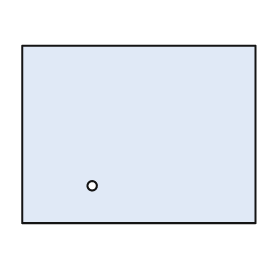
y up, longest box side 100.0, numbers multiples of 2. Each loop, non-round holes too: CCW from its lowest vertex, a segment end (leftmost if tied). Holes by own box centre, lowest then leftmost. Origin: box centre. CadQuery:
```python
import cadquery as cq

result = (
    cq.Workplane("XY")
    .moveTo(-50.0, -38.0)
    .lineTo(50.0, -38.0)
    .lineTo(50.0, 38.0)
    .lineTo(-50.0, 38.0)
    .close()
    .moveTo(-20.0, -22.0)
    .circle(2.0)
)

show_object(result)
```